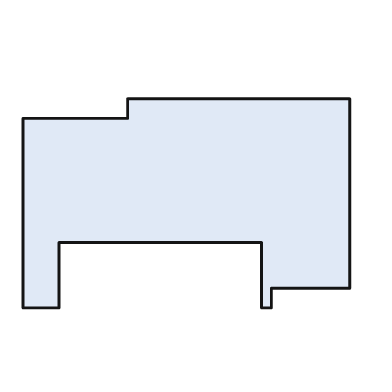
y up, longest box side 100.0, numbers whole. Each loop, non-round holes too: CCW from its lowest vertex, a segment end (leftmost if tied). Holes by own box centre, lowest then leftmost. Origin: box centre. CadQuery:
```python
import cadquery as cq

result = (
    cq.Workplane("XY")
    .moveTo(-50.0, -32.0)
    .lineTo(-39.0, -32.0)
    .lineTo(-39.0, -12.0)
    .lineTo(23.0, -12.0)
    .lineTo(23.0, -32.0)
    .lineTo(26.0, -32.0)
    .lineTo(26.0, -26.0)
    .lineTo(50.0, -26.0)
    .lineTo(50.0, 32.0)
    .lineTo(-18.0, 32.0)
    .lineTo(-18.0, 26.0)
    .lineTo(-50.0, 26.0)
    .close()
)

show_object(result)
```